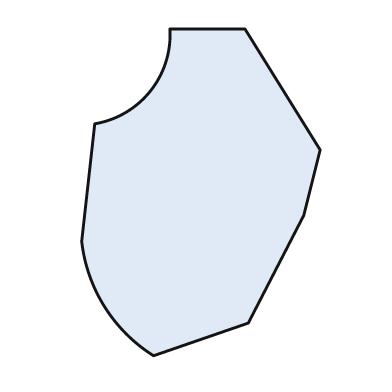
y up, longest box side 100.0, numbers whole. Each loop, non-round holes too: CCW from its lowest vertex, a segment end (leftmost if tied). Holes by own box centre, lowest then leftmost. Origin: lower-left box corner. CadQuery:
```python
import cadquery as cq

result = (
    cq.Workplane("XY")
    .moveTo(22.0, 0.0)
    .lineTo(51.0, 10.0)
    .lineTo(68.0, 43.0)
    .lineTo(73.0, 63.0)
    .lineTo(50.0, 100.0)
    .lineTo(27.0, 100.0)
    .threePointArc((21.0, 81.0), (4.0, 71.0))
    .lineTo(0.0, 35.0)
    .threePointArc((7.0, 15.0), (22.0, 0.0))
    .close()
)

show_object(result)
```